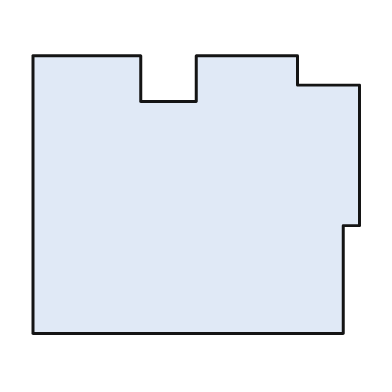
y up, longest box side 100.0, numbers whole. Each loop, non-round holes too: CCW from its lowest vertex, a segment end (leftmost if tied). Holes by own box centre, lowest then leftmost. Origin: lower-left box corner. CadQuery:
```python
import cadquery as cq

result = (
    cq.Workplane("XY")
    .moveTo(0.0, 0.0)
    .lineTo(95.0, 0.0)
    .lineTo(95.0, 33.0)
    .lineTo(100.0, 33.0)
    .lineTo(100.0, 76.0)
    .lineTo(81.0, 76.0)
    .lineTo(81.0, 85.0)
    .lineTo(50.0, 85.0)
    .lineTo(50.0, 71.0)
    .lineTo(33.0, 71.0)
    .lineTo(33.0, 85.0)
    .lineTo(0.0, 85.0)
    .close()
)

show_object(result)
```